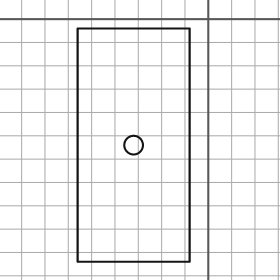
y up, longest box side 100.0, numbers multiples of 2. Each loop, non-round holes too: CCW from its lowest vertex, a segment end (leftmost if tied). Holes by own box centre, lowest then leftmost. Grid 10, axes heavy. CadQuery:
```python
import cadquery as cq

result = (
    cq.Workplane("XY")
    .moveTo(-56.0, -104.0)
    .lineTo(-8.0, -104.0)
    .lineTo(-8.0, -4.0)
    .lineTo(-56.0, -4.0)
    .close()
    .moveTo(-32.0, -54.0)
    .circle(4.0)
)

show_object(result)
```